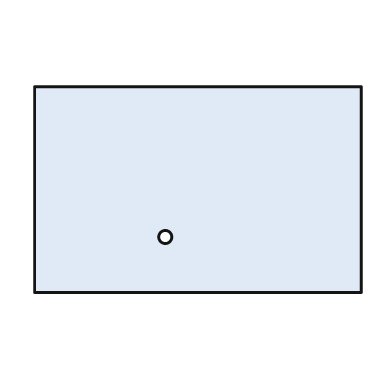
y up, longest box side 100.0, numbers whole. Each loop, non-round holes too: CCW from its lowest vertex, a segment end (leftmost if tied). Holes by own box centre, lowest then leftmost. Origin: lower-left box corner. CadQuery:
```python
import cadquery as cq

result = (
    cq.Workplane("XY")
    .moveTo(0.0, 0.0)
    .lineTo(100.0, 0.0)
    .lineTo(100.0, 63.0)
    .lineTo(0.0, 63.0)
    .close()
    .moveTo(40.0, 17.0)
    .circle(2.0)
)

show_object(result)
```